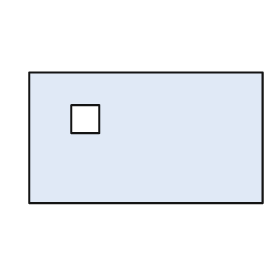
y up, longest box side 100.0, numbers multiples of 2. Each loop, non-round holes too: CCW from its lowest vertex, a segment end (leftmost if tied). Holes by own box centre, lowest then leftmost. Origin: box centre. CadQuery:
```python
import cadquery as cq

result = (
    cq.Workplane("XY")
    .moveTo(-50.0, -28.0)
    .lineTo(50.0, -28.0)
    .lineTo(50.0, 28.0)
    .lineTo(-50.0, 28.0)
    .close()
    .moveTo(-32.0, 2.0)
    .lineTo(-20.0, 2.0)
    .lineTo(-20.0, 14.0)
    .lineTo(-32.0, 14.0)
    .close()
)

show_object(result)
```